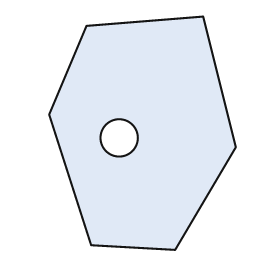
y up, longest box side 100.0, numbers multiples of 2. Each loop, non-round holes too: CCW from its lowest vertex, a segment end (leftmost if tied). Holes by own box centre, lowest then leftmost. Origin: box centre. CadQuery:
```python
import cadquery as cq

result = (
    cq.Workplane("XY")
    .moveTo(14.0, -50.0)
    .lineTo(40.0, -6.0)
    .lineTo(26.0, 50.0)
    .lineTo(-24.0, 46.0)
    .lineTo(-40.0, 8.0)
    .lineTo(-22.0, -48.0)
    .close()
    .moveTo(-10.0, -2.0)
    .circle(8.0)
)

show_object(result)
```